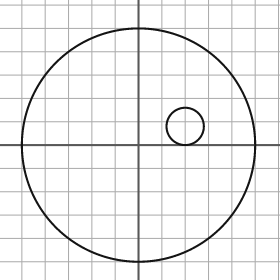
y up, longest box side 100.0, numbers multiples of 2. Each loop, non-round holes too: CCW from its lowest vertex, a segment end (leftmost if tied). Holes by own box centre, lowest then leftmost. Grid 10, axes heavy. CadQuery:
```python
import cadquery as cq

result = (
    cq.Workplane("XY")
    .moveTo(0.0, 0.0)
    .circle(50.0)
    .moveTo(20.0, 8.0)
    .circle(8.0)
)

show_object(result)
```